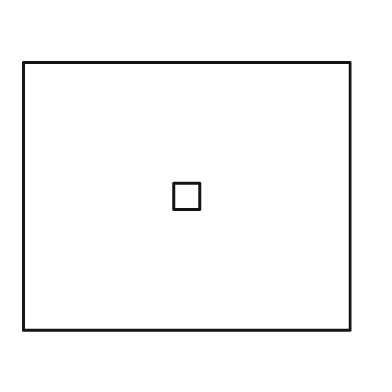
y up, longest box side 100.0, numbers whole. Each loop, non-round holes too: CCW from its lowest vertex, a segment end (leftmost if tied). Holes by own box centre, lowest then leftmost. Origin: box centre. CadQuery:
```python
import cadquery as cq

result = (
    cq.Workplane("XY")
    .moveTo(-50.0, -41.0)
    .lineTo(50.0, -41.0)
    .lineTo(50.0, 41.0)
    .lineTo(-50.0, 41.0)
    .close()
    .moveTo(-4.0, -4.0)
    .lineTo(4.0, -4.0)
    .lineTo(4.0, 4.0)
    .lineTo(-4.0, 4.0)
    .close()
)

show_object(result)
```